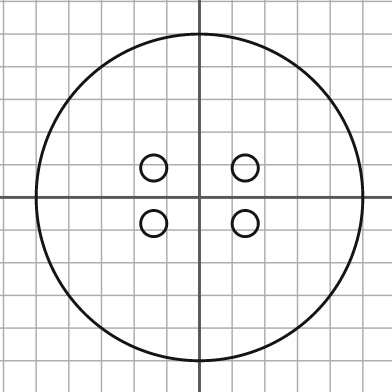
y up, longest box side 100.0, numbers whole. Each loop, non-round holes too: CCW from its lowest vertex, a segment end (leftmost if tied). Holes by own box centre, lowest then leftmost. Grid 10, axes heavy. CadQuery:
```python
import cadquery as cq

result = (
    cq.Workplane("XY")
    .moveTo(0.0, 0.0)
    .circle(50.0)
    .moveTo(-14.0, -8.0)
    .circle(4.0)
    .moveTo(14.0, -8.0)
    .circle(4.0)
    .moveTo(-14.0, 9.0)
    .circle(4.0)
    .moveTo(14.0, 9.0)
    .circle(4.0)
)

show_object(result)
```